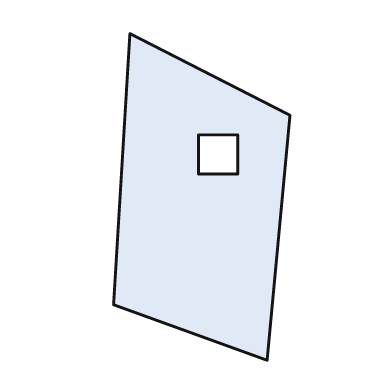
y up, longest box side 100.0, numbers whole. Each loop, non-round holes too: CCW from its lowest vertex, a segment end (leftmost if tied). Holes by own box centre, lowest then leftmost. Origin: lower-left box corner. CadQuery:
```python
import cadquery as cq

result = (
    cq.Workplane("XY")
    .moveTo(47.0, 0.0)
    .lineTo(54.0, 75.0)
    .lineTo(5.0, 100.0)
    .lineTo(0.0, 17.0)
    .close()
    .moveTo(26.0, 57.0)
    .lineTo(38.0, 57.0)
    .lineTo(38.0, 69.0)
    .lineTo(26.0, 69.0)
    .close()
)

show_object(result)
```